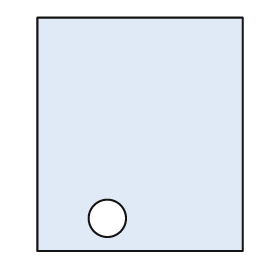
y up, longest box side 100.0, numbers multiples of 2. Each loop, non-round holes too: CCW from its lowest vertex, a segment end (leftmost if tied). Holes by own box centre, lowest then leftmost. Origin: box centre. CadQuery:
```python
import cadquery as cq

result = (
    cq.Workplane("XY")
    .moveTo(-44.0, -50.0)
    .lineTo(44.0, -50.0)
    .lineTo(44.0, 50.0)
    .lineTo(-44.0, 50.0)
    .close()
    .moveTo(-14.0, -36.0)
    .circle(8.0)
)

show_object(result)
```